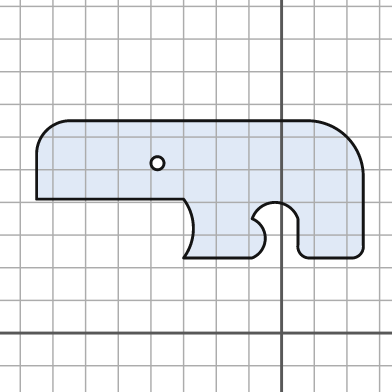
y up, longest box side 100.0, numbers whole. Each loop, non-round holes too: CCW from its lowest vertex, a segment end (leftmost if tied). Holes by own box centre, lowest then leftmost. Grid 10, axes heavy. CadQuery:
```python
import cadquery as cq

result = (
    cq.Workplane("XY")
    .moveTo(-30.0, 23.0)
    .lineTo(-9.0, 23.0)
    .threePointArc((-5.0, 29.0), (-9.0, 35.0))
    .threePointArc((-2.0, 40.0), (5.0, 35.0))
    .lineTo(5.0, 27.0)
    .threePointArc((6.0, 24.0), (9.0, 23.0))
    .lineTo(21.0, 23.0)
    .threePointArc((24.0, 24.0), (25.0, 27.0))
    .lineTo(25.0, 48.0)
    .threePointArc((20.0, 60.0), (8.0, 65.0))
    .lineTo(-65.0, 65.0)
    .threePointArc((-72.0, 62.0), (-75.0, 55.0))
    .lineTo(-75.0, 41.0)
    .lineTo(-30.0, 41.0)
    .threePointArc((-27.0, 32.0), (-30.0, 23.0))
    .close()
    .moveTo(-38.0, 52.0)
    .circle(2.0)
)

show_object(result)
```